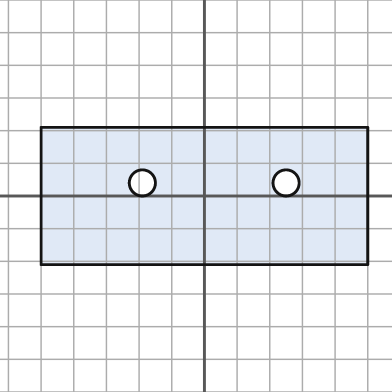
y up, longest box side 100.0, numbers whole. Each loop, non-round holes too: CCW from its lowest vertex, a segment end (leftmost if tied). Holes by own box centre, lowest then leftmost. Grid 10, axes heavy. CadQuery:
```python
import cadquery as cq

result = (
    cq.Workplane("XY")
    .moveTo(-50.0, -21.0)
    .lineTo(50.0, -21.0)
    .lineTo(50.0, 21.0)
    .lineTo(-50.0, 21.0)
    .close()
    .moveTo(-19.0, 4.0)
    .circle(4.0)
    .moveTo(25.0, 4.0)
    .circle(4.0)
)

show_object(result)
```